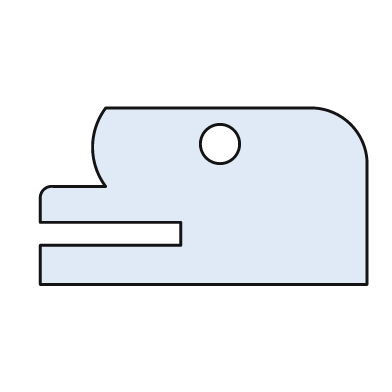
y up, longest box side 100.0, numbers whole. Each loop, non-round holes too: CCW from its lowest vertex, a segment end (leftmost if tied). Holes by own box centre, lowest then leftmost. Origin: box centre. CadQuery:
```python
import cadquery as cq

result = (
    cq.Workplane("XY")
    .moveTo(-50.0, -27.0)
    .lineTo(50.0, -27.0)
    .lineTo(50.0, 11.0)
    .threePointArc((45.0, 22.0), (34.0, 27.0))
    .lineTo(-30.0, 27.0)
    .threePointArc((-34.0, 15.0), (-30.0, 3.0))
    .lineTo(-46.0, 3.0)
    .threePointArc((-49.0, 2.0), (-50.0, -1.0))
    .lineTo(-50.0, -8.0)
    .lineTo(-7.0, -8.0)
    .lineTo(-7.0, -15.0)
    .lineTo(-50.0, -15.0)
    .close()
    .moveTo(5.0, 16.0)
    .circle(6.0)
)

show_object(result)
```